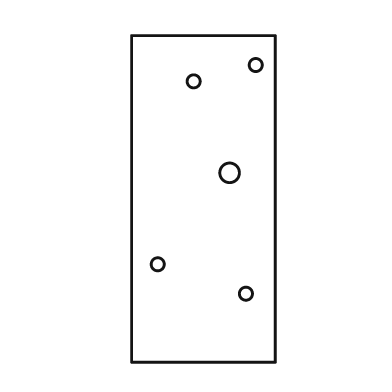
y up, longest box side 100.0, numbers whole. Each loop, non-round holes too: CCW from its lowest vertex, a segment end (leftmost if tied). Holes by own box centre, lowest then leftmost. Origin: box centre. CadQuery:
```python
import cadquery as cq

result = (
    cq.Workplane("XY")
    .moveTo(-22.0, -50.0)
    .lineTo(22.0, -50.0)
    .lineTo(22.0, 50.0)
    .lineTo(-22.0, 50.0)
    .close()
    .moveTo(13.0, -29.0)
    .circle(2.0)
    .moveTo(-14.0, -20.0)
    .circle(2.0)
    .moveTo(8.0, 8.0)
    .circle(3.0)
    .moveTo(-3.0, 36.0)
    .circle(2.0)
    .moveTo(16.0, 41.0)
    .circle(2.0)
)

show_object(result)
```